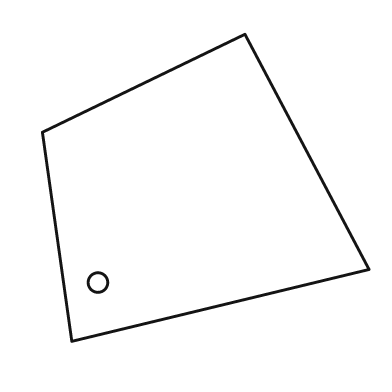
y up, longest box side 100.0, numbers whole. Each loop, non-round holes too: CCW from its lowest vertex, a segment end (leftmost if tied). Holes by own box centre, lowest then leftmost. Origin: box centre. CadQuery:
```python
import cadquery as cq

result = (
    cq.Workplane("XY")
    .moveTo(-41.0, -47.0)
    .lineTo(50.0, -25.0)
    .lineTo(12.0, 47.0)
    .lineTo(-50.0, 17.0)
    .close()
    .moveTo(-33.0, -29.0)
    .circle(3.0)
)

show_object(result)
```